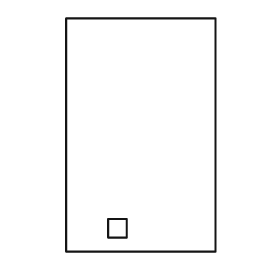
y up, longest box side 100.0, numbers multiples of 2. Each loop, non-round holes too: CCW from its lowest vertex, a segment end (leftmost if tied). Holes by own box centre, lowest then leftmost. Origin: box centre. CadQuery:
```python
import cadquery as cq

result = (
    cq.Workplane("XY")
    .moveTo(-32.0, -50.0)
    .lineTo(32.0, -50.0)
    .lineTo(32.0, 50.0)
    .lineTo(-32.0, 50.0)
    .close()
    .moveTo(-14.0, -44.0)
    .lineTo(-6.0, -44.0)
    .lineTo(-6.0, -36.0)
    .lineTo(-14.0, -36.0)
    .close()
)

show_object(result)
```